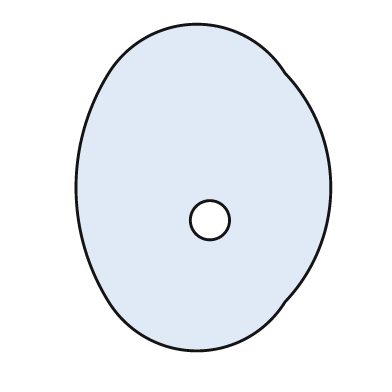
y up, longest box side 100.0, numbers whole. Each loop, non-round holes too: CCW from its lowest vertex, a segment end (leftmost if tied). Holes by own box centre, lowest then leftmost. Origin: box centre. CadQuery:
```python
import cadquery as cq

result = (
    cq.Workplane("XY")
    .moveTo(-29.0, -35.0)
    .threePointArc((-2.0, -50.0), (25.0, -35.0))
    .threePointArc((39.0, 0.0), (25.0, 35.0))
    .threePointArc((-2.0, 50.0), (-29.0, 35.0))
    .threePointArc((-39.0, 0.0), (-29.0, -35.0))
    .close()
    .moveTo(2.0, -10.0)
    .circle(6.0)
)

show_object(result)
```